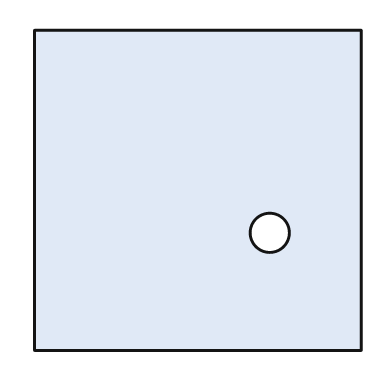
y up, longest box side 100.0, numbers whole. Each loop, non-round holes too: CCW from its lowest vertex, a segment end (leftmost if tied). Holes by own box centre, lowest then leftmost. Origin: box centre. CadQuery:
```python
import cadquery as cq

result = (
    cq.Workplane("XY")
    .moveTo(-50.0, -49.0)
    .lineTo(50.0, -49.0)
    .lineTo(50.0, 49.0)
    .lineTo(-50.0, 49.0)
    .close()
    .moveTo(22.0, -13.0)
    .circle(6.0)
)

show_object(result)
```